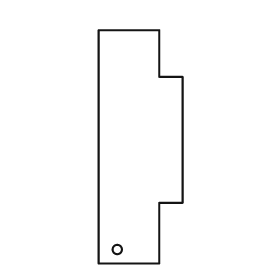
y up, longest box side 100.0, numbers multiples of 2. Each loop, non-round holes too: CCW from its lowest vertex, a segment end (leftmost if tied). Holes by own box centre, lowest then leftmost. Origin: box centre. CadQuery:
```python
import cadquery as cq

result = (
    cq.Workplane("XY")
    .moveTo(-18.0, -50.0)
    .lineTo(8.0, -50.0)
    .lineTo(8.0, -24.0)
    .lineTo(18.0, -24.0)
    .lineTo(18.0, 30.0)
    .lineTo(8.0, 30.0)
    .lineTo(8.0, 50.0)
    .lineTo(-18.0, 50.0)
    .close()
    .moveTo(-10.0, -44.0)
    .circle(2.0)
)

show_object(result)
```